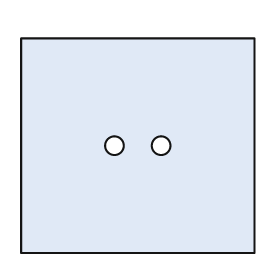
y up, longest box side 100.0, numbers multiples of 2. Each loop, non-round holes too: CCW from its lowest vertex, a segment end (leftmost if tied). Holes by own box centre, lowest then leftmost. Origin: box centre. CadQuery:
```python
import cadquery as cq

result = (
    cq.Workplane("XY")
    .moveTo(-50.0, -46.0)
    .lineTo(50.0, -46.0)
    .lineTo(50.0, 46.0)
    .lineTo(-50.0, 46.0)
    .close()
    .moveTo(-10.0, 0.0)
    .circle(4.0)
    .moveTo(10.0, 0.0)
    .circle(4.0)
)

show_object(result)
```